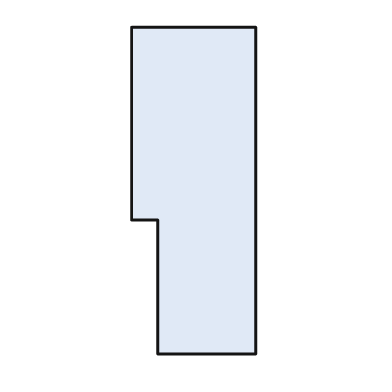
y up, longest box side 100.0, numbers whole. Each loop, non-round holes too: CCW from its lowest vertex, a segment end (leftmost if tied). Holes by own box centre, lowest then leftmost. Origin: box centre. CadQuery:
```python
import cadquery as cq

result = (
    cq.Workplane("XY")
    .moveTo(-11.0, -50.0)
    .lineTo(19.0, -50.0)
    .lineTo(19.0, 50.0)
    .lineTo(-19.0, 50.0)
    .lineTo(-19.0, -9.0)
    .lineTo(-11.0, -9.0)
    .close()
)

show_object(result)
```